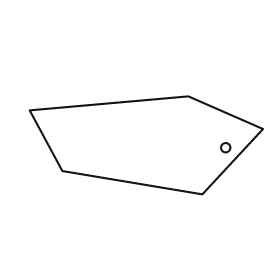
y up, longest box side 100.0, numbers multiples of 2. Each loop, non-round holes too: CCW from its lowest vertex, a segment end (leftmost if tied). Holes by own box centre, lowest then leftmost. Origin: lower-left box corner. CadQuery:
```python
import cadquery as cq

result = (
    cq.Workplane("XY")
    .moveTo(74.0, 0.0)
    .lineTo(100.0, 28.0)
    .lineTo(68.0, 42.0)
    .lineTo(0.0, 36.0)
    .lineTo(14.0, 10.0)
    .close()
    .moveTo(84.0, 20.0)
    .circle(2.0)
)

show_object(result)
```